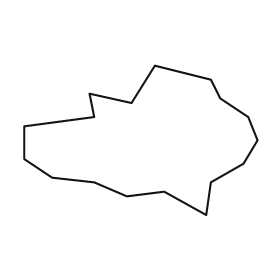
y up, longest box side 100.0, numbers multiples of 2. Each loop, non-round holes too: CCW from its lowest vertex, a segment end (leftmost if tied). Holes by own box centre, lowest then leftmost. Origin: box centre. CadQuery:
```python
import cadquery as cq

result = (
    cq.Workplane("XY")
    .moveTo(28.0, -32.0)
    .lineTo(30.0, -18.0)
    .lineTo(44.0, -10.0)
    .lineTo(50.0, 0.0)
    .lineTo(46.0, 10.0)
    .lineTo(34.0, 18.0)
    .lineTo(30.0, 26.0)
    .lineTo(6.0, 32.0)
    .lineTo(-4.0, 16.0)
    .lineTo(-22.0, 20.0)
    .lineTo(-20.0, 10.0)
    .lineTo(-50.0, 6.0)
    .lineTo(-50.0, -8.0)
    .lineTo(-38.0, -16.0)
    .lineTo(-20.0, -18.0)
    .lineTo(-6.0, -24.0)
    .lineTo(10.0, -22.0)
    .close()
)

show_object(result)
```